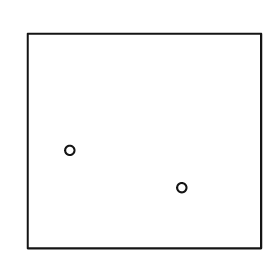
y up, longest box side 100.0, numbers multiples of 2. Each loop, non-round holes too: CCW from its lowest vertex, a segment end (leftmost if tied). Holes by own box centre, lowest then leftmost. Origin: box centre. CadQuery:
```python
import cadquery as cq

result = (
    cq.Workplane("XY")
    .moveTo(-50.0, -46.0)
    .lineTo(50.0, -46.0)
    .lineTo(50.0, 46.0)
    .lineTo(-50.0, 46.0)
    .close()
    .moveTo(16.0, -20.0)
    .circle(2.0)
    .moveTo(-32.0, -4.0)
    .circle(2.0)
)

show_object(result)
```